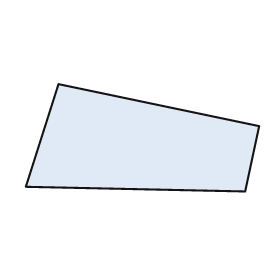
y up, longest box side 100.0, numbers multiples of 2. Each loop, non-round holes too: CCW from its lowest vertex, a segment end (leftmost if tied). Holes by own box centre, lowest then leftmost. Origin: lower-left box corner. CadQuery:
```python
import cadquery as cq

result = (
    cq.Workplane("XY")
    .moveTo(94.0, 0.0)
    .lineTo(100.0, 28.0)
    .lineTo(14.0, 46.0)
    .lineTo(0.0, 2.0)
    .close()
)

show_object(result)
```